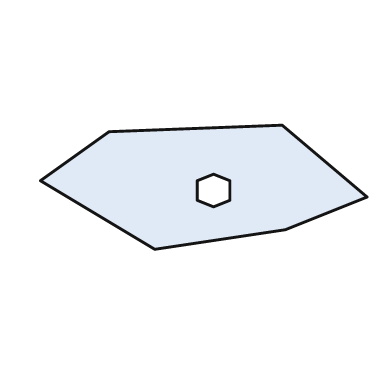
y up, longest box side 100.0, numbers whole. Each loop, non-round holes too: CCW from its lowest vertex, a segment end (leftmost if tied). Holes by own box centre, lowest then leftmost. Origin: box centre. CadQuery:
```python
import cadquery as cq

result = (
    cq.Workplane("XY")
    .moveTo(-15.0, -19.0)
    .lineTo(25.0, -13.0)
    .lineTo(50.0, -3.0)
    .lineTo(24.0, 19.0)
    .lineTo(-29.0, 17.0)
    .lineTo(-50.0, 2.0)
    .close()
    .moveTo(3.0, -6.0)
    .lineTo(8.0, -4.0)
    .lineTo(8.0, 2.0)
    .lineTo(3.0, 4.0)
    .lineTo(-2.0, 2.0)
    .lineTo(-2.0, -4.0)
    .close()
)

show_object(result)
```